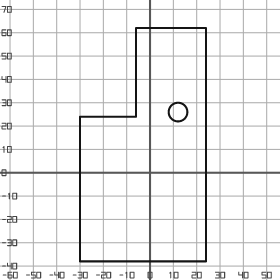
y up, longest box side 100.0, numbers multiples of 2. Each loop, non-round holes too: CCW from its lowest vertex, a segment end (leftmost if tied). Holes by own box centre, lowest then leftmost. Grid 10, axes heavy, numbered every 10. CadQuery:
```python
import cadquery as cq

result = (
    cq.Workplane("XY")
    .moveTo(-30.0, -38.0)
    .lineTo(24.0, -38.0)
    .lineTo(24.0, 62.0)
    .lineTo(-6.0, 62.0)
    .lineTo(-6.0, 24.0)
    .lineTo(-30.0, 24.0)
    .close()
    .moveTo(12.0, 26.0)
    .circle(4.0)
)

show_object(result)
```